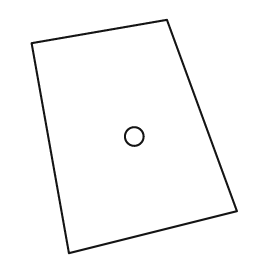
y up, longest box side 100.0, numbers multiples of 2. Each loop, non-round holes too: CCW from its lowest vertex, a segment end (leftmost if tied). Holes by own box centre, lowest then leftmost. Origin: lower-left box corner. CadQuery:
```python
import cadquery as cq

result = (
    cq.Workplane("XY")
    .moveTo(16.0, 0.0)
    .lineTo(88.0, 18.0)
    .lineTo(58.0, 100.0)
    .lineTo(0.0, 90.0)
    .close()
    .moveTo(44.0, 50.0)
    .circle(4.0)
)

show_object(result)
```